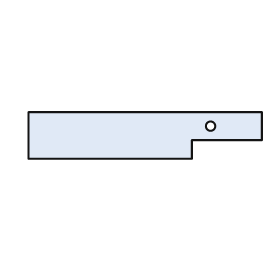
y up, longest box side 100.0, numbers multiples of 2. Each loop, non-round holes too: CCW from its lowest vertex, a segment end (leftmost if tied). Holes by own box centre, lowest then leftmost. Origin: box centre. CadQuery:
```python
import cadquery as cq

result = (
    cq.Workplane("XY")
    .moveTo(-50.0, -10.0)
    .lineTo(20.0, -10.0)
    .lineTo(20.0, -2.0)
    .lineTo(50.0, -2.0)
    .lineTo(50.0, 10.0)
    .lineTo(-50.0, 10.0)
    .close()
    .moveTo(28.0, 4.0)
    .circle(2.0)
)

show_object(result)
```